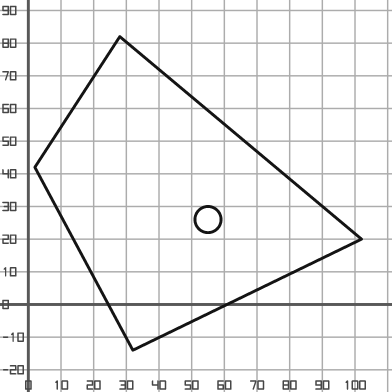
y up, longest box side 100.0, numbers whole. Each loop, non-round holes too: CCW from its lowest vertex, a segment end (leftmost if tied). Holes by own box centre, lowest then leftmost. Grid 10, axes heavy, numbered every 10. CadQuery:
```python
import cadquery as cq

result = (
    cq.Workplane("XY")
    .moveTo(32.0, -14.0)
    .lineTo(102.0, 20.0)
    .lineTo(28.0, 82.0)
    .lineTo(2.0, 42.0)
    .close()
    .moveTo(55.0, 26.0)
    .circle(4.0)
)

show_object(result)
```